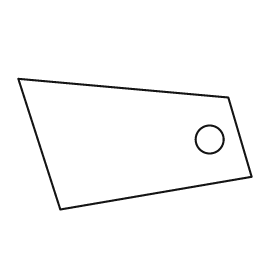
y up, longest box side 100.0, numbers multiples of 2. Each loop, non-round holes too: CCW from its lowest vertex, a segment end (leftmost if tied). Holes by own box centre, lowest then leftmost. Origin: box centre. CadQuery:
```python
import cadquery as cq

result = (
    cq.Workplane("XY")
    .moveTo(-32.0, -28.0)
    .lineTo(50.0, -14.0)
    .lineTo(40.0, 20.0)
    .lineTo(-50.0, 28.0)
    .close()
    .moveTo(32.0, 2.0)
    .circle(6.0)
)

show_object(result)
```